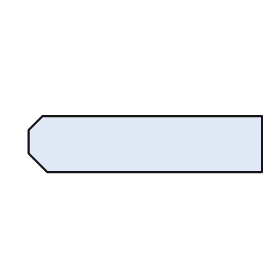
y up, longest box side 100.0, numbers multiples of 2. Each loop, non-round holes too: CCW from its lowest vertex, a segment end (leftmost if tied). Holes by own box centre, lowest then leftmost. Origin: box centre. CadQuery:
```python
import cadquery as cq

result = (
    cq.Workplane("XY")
    .moveTo(-42.0, -12.0)
    .lineTo(50.0, -12.0)
    .lineTo(50.0, 12.0)
    .lineTo(-44.0, 12.0)
    .lineTo(-50.0, 6.0)
    .lineTo(-50.0, -4.0)
    .close()
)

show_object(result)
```